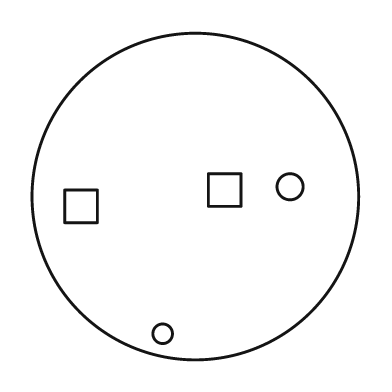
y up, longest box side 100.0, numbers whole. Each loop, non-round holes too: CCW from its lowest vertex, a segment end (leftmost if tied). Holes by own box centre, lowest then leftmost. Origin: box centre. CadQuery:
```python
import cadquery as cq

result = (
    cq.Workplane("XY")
    .moveTo(0.0, 0.0)
    .circle(50.0)
    .moveTo(-10.0, -42.0)
    .circle(3.0)
    .moveTo(-40.0, -8.0)
    .lineTo(-30.0, -8.0)
    .lineTo(-30.0, 2.0)
    .lineTo(-40.0, 2.0)
    .close()
    .moveTo(4.0, -3.0)
    .lineTo(14.0, -3.0)
    .lineTo(14.0, 7.0)
    .lineTo(4.0, 7.0)
    .close()
    .moveTo(29.0, 3.0)
    .circle(4.0)
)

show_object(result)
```